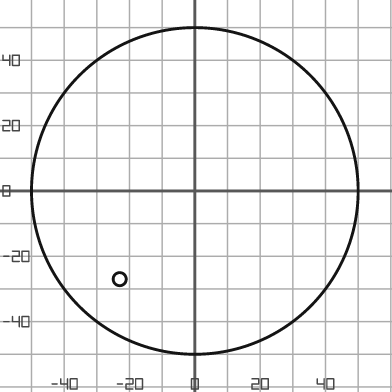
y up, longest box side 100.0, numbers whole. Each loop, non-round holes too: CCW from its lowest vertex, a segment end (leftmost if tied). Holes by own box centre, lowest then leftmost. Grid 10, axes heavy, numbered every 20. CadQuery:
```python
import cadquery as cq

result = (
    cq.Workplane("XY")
    .moveTo(0.0, 0.0)
    .circle(50.0)
    .moveTo(-23.0, -27.0)
    .circle(2.0)
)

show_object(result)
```